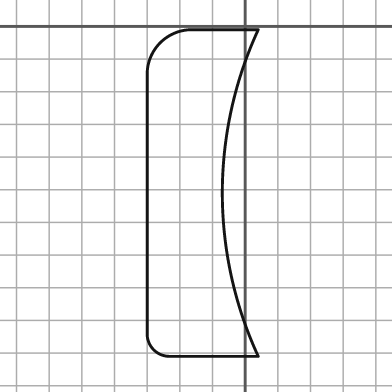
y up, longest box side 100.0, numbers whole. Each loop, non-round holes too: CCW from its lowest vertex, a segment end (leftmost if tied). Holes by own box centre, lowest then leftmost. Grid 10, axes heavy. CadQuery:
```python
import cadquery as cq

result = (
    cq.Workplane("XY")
    .moveTo(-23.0, -101.0)
    .lineTo(4.0, -101.0)
    .threePointArc((-7.0, -51.0), (4.0, -1.0))
    .lineTo(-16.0, -1.0)
    .threePointArc((-26.0, -5.0), (-30.0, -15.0))
    .lineTo(-30.0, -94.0)
    .threePointArc((-28.0, -99.0), (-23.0, -101.0))
    .close()
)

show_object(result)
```